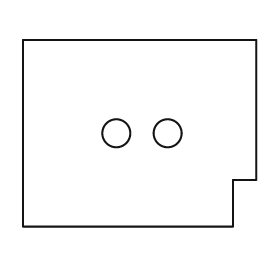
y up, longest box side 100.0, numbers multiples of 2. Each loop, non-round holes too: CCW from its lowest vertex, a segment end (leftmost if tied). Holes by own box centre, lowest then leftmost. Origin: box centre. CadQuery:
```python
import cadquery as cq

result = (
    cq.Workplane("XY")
    .moveTo(-50.0, -40.0)
    .lineTo(40.0, -40.0)
    .lineTo(40.0, -20.0)
    .lineTo(50.0, -20.0)
    .lineTo(50.0, 40.0)
    .lineTo(-50.0, 40.0)
    .close()
    .moveTo(-10.0, 0.0)
    .circle(6.0)
    .moveTo(12.0, 0.0)
    .circle(6.0)
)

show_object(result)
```